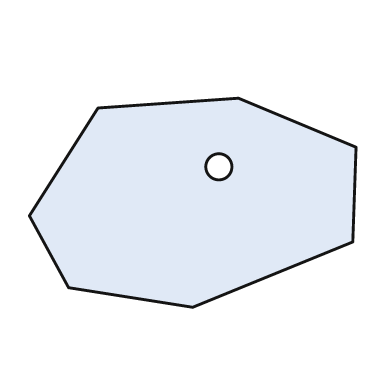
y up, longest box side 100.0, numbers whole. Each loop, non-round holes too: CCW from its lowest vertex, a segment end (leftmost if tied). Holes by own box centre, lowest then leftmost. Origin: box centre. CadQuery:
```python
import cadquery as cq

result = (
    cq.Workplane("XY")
    .moveTo(0.0, -32.0)
    .lineTo(49.0, -12.0)
    .lineTo(50.0, 17.0)
    .lineTo(14.0, 32.0)
    .lineTo(-29.0, 29.0)
    .lineTo(-50.0, -4.0)
    .lineTo(-38.0, -26.0)
    .close()
    .moveTo(8.0, 11.0)
    .circle(4.0)
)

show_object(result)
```